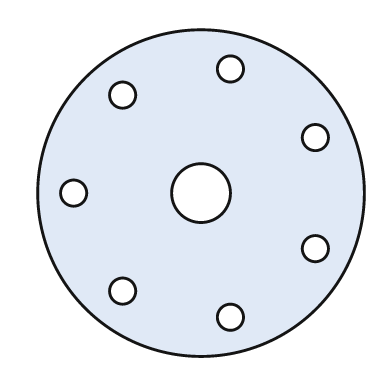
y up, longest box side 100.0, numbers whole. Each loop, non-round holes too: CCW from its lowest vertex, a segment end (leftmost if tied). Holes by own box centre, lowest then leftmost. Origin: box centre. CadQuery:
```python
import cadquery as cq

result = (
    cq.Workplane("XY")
    .moveTo(0.0, 0.0)
    .circle(50.0)
    .moveTo(9.0, -38.0)
    .circle(4.0)
    .moveTo(-24.0, -30.0)
    .circle(4.0)
    .moveTo(35.0, -17.0)
    .circle(4.0)
    .moveTo(-39.0, 0.0)
    .circle(4.0)
    .moveTo(0.0, 0.0)
    .circle(9.0)
    .moveTo(35.0, 17.0)
    .circle(4.0)
    .moveTo(-24.0, 30.0)
    .circle(4.0)
    .moveTo(9.0, 38.0)
    .circle(4.0)
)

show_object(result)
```